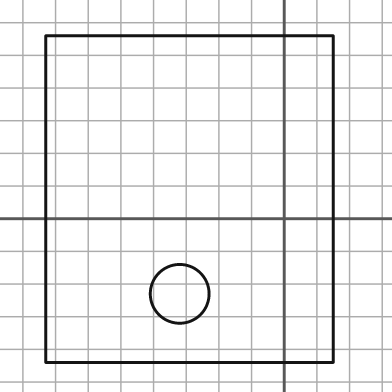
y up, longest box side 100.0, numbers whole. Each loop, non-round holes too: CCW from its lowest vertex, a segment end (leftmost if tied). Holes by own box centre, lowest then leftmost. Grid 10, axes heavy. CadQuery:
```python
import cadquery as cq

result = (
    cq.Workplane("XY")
    .moveTo(-73.0, -44.0)
    .lineTo(15.0, -44.0)
    .lineTo(15.0, 56.0)
    .lineTo(-73.0, 56.0)
    .close()
    .moveTo(-32.0, -23.0)
    .circle(9.0)
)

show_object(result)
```